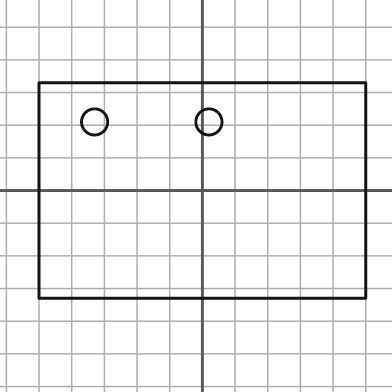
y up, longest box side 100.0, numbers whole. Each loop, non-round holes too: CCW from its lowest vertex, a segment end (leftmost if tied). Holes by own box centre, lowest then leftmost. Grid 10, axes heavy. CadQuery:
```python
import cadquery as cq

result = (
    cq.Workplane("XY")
    .moveTo(-50.0, -33.0)
    .lineTo(50.0, -33.0)
    .lineTo(50.0, 33.0)
    .lineTo(-50.0, 33.0)
    .close()
    .moveTo(-33.0, 21.0)
    .circle(4.0)
    .moveTo(2.0, 21.0)
    .circle(4.0)
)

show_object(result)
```